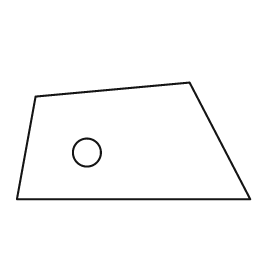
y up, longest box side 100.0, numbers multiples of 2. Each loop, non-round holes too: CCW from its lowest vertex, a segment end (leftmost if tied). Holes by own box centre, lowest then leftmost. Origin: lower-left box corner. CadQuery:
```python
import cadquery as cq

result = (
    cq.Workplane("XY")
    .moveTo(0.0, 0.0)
    .lineTo(100.0, 0.0)
    .lineTo(74.0, 50.0)
    .lineTo(8.0, 44.0)
    .close()
    .moveTo(30.0, 20.0)
    .circle(6.0)
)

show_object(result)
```